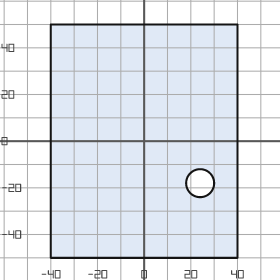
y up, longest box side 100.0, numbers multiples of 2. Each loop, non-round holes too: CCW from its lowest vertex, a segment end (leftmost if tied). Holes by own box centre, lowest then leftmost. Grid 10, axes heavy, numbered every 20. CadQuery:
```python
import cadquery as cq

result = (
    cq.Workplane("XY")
    .moveTo(-40.0, -50.0)
    .lineTo(40.0, -50.0)
    .lineTo(40.0, 50.0)
    .lineTo(-40.0, 50.0)
    .close()
    .moveTo(24.0, -18.0)
    .circle(6.0)
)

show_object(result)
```